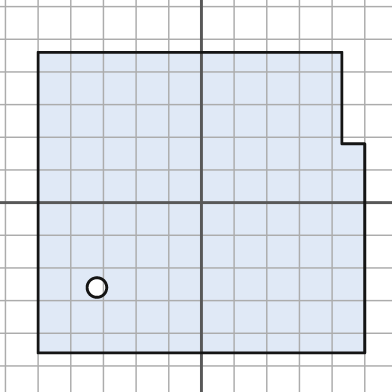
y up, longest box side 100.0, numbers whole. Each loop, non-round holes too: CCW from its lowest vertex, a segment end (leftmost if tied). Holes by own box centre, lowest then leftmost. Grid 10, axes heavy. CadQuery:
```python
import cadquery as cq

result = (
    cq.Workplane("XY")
    .moveTo(-50.0, -46.0)
    .lineTo(50.0, -46.0)
    .lineTo(50.0, 18.0)
    .lineTo(43.0, 18.0)
    .lineTo(43.0, 46.0)
    .lineTo(-50.0, 46.0)
    .close()
    .moveTo(-32.0, -26.0)
    .circle(3.0)
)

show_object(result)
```